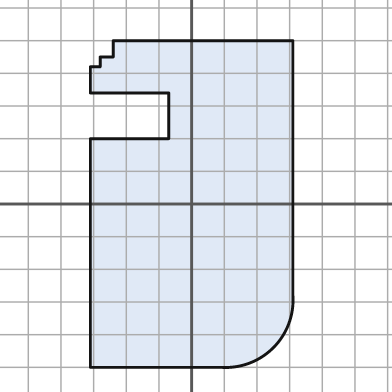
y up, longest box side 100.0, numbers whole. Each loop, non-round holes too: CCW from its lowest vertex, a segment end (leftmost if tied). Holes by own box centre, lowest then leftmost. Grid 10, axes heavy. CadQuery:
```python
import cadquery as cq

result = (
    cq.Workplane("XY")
    .moveTo(-31.0, -50.0)
    .lineTo(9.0, -50.0)
    .threePointArc((25.0, -44.0), (31.0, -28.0))
    .lineTo(31.0, 50.0)
    .lineTo(-24.0, 50.0)
    .lineTo(-24.0, 45.0)
    .lineTo(-28.0, 45.0)
    .lineTo(-28.0, 42.0)
    .lineTo(-31.0, 42.0)
    .lineTo(-31.0, 34.0)
    .lineTo(-7.0, 34.0)
    .lineTo(-7.0, 20.0)
    .lineTo(-31.0, 20.0)
    .close()
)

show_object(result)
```